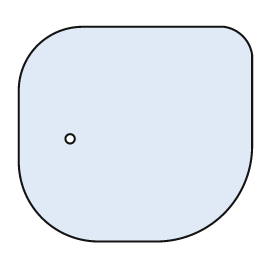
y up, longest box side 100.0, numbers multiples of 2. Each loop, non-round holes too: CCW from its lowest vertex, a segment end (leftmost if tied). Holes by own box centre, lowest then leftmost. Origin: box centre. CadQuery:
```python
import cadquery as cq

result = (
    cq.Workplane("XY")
    .moveTo(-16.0, -46.0)
    .lineTo(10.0, -46.0)
    .threePointArc((38.0, -34.0), (50.0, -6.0))
    .lineTo(50.0, 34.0)
    .threePointArc((46.0, 42.0), (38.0, 46.0))
    .lineTo(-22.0, 46.0)
    .threePointArc((-42.0, 38.0), (-50.0, 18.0))
    .lineTo(-50.0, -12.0)
    .threePointArc((-40.0, -36.0), (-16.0, -46.0))
    .close()
    .moveTo(-28.0, -2.0)
    .circle(2.0)
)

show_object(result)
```